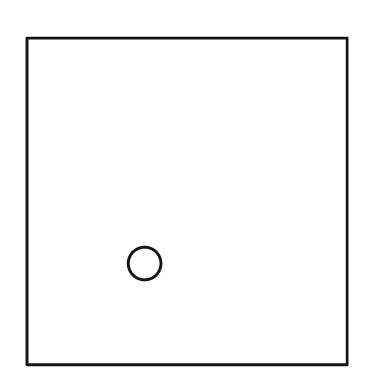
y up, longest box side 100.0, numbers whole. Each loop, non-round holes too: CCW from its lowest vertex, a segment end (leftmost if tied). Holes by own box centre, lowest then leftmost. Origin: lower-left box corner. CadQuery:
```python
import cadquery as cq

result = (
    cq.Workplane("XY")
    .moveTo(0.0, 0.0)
    .lineTo(98.0, 0.0)
    .lineTo(98.0, 100.0)
    .lineTo(0.0, 100.0)
    .close()
    .moveTo(36.0, 31.0)
    .circle(5.0)
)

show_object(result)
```